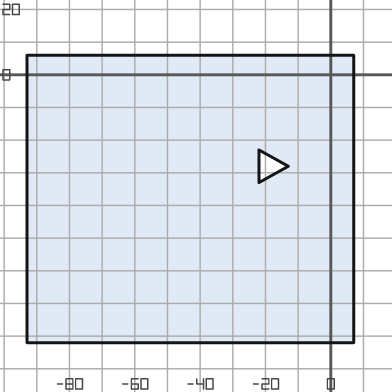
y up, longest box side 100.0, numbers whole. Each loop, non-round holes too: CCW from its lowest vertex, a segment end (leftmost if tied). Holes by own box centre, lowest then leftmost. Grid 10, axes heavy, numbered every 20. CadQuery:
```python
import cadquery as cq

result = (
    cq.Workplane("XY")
    .moveTo(-93.0, -82.0)
    .lineTo(7.0, -82.0)
    .lineTo(7.0, 6.0)
    .lineTo(-93.0, 6.0)
    .close()
    .moveTo(-22.0, -33.0)
    .lineTo(-13.0, -28.0)
    .lineTo(-22.0, -23.0)
    .close()
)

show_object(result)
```